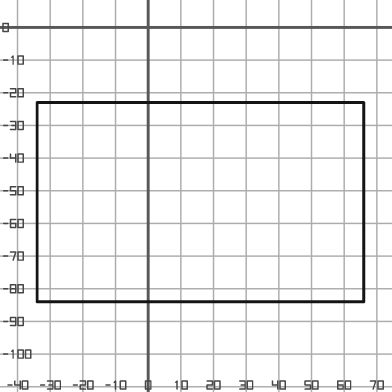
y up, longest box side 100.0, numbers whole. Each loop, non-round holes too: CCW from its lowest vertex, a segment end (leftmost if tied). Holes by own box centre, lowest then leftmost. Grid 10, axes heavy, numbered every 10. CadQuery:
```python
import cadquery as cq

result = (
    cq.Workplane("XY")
    .moveTo(-34.0, -84.0)
    .lineTo(66.0, -84.0)
    .lineTo(66.0, -23.0)
    .lineTo(-34.0, -23.0)
    .close()
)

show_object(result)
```